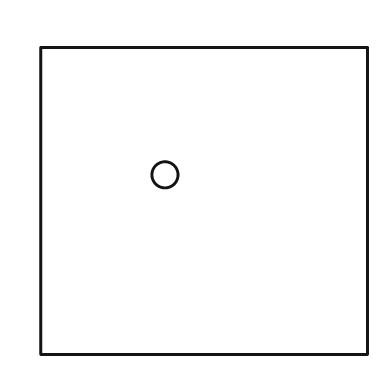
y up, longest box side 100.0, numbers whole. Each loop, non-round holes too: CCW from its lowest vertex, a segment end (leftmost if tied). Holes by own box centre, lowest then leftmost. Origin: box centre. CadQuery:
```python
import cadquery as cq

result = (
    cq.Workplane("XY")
    .moveTo(-50.0, -47.0)
    .lineTo(50.0, -47.0)
    .lineTo(50.0, 47.0)
    .lineTo(-50.0, 47.0)
    .close()
    .moveTo(-12.0, 8.0)
    .circle(4.0)
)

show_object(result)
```